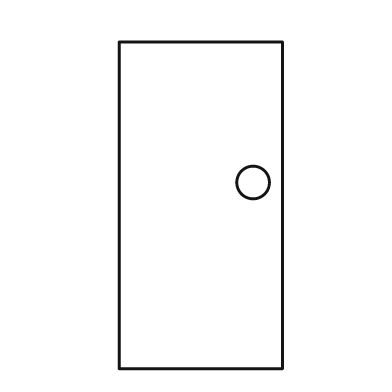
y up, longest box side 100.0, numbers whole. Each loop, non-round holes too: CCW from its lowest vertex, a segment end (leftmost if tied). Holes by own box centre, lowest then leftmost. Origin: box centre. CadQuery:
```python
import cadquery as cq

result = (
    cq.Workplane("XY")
    .moveTo(-25.0, -50.0)
    .lineTo(25.0, -50.0)
    .lineTo(25.0, 50.0)
    .lineTo(-25.0, 50.0)
    .close()
    .moveTo(16.0, 7.0)
    .circle(5.0)
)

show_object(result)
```